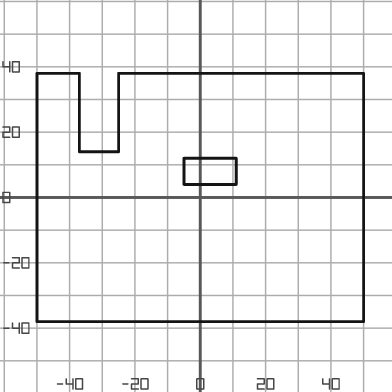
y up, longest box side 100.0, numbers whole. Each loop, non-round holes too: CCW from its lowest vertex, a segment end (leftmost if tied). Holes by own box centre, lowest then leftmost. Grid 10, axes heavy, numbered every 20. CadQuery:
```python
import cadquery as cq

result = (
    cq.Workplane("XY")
    .moveTo(-50.0, -38.0)
    .lineTo(50.0, -38.0)
    .lineTo(50.0, 38.0)
    .lineTo(-25.0, 38.0)
    .lineTo(-25.0, 14.0)
    .lineTo(-37.0, 14.0)
    .lineTo(-37.0, 38.0)
    .lineTo(-50.0, 38.0)
    .close()
    .moveTo(-5.0, 4.0)
    .lineTo(11.0, 4.0)
    .lineTo(11.0, 12.0)
    .lineTo(-5.0, 12.0)
    .close()
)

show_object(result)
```